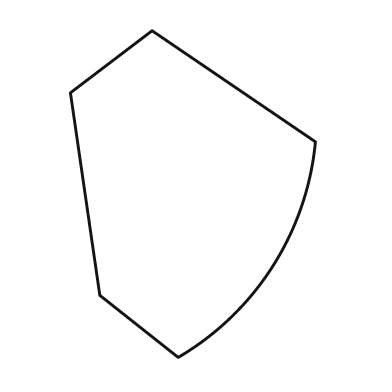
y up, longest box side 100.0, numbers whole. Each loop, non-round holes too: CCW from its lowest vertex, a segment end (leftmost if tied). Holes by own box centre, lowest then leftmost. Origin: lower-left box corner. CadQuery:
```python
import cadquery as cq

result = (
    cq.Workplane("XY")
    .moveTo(33.0, 0.0)
    .threePointArc((62.0, 28.0), (75.0, 66.0))
    .lineTo(25.0, 100.0)
    .lineTo(0.0, 81.0)
    .lineTo(9.0, 19.0)
    .close()
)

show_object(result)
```